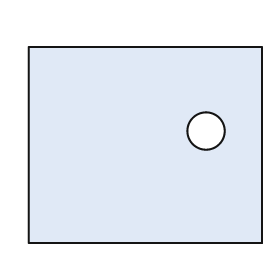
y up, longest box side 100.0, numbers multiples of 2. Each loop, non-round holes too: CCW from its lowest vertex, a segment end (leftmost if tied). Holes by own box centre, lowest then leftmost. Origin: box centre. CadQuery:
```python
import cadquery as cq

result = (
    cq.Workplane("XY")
    .moveTo(-50.0, -42.0)
    .lineTo(50.0, -42.0)
    .lineTo(50.0, 42.0)
    .lineTo(-50.0, 42.0)
    .close()
    .moveTo(26.0, 6.0)
    .circle(8.0)
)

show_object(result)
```